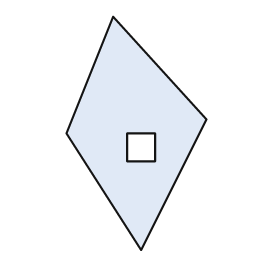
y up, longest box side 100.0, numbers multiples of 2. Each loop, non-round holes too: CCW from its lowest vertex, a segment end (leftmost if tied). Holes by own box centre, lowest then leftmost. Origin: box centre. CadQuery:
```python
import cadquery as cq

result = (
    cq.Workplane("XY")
    .moveTo(2.0, -50.0)
    .lineTo(30.0, 6.0)
    .lineTo(-10.0, 50.0)
    .lineTo(-30.0, 0.0)
    .close()
    .moveTo(-4.0, -12.0)
    .lineTo(8.0, -12.0)
    .lineTo(8.0, 0.0)
    .lineTo(-4.0, 0.0)
    .close()
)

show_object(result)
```